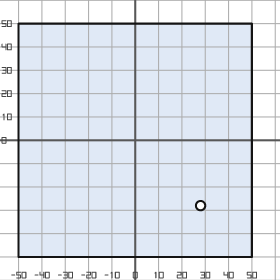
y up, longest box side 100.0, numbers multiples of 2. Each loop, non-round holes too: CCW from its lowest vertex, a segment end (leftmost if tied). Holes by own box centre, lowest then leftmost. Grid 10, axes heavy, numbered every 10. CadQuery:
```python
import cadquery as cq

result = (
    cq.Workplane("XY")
    .moveTo(-50.0, -50.0)
    .lineTo(50.0, -50.0)
    .lineTo(50.0, 50.0)
    .lineTo(-50.0, 50.0)
    .close()
    .moveTo(28.0, -28.0)
    .circle(2.0)
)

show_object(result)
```